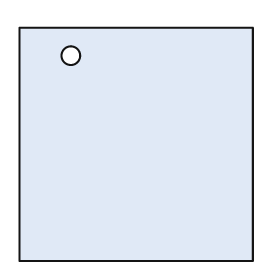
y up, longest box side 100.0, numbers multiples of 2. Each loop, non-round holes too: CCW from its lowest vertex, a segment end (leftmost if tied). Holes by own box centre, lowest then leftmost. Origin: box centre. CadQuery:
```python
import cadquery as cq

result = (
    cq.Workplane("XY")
    .moveTo(-50.0, -50.0)
    .lineTo(50.0, -50.0)
    .lineTo(50.0, 50.0)
    .lineTo(-50.0, 50.0)
    .close()
    .moveTo(-28.0, 38.0)
    .circle(4.0)
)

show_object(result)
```